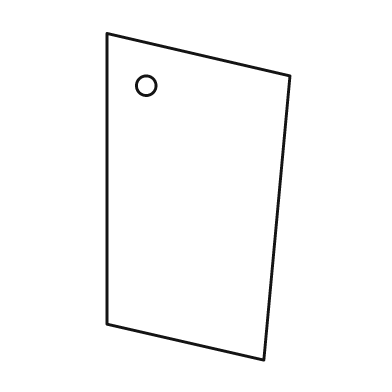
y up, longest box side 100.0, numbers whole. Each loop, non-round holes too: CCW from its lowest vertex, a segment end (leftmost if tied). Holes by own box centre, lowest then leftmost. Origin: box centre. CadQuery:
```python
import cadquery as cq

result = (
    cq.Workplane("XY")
    .moveTo(20.0, -50.0)
    .lineTo(28.0, 37.0)
    .lineTo(-28.0, 50.0)
    .lineTo(-28.0, -39.0)
    .close()
    .moveTo(-16.0, 34.0)
    .circle(3.0)
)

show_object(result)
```